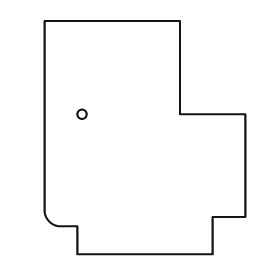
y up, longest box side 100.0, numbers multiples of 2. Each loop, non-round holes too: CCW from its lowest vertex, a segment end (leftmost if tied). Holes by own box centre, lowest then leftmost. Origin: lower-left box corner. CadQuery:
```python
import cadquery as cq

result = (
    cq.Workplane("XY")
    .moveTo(14.0, 0.0)
    .lineTo(72.0, 0.0)
    .lineTo(72.0, 16.0)
    .lineTo(86.0, 16.0)
    .lineTo(86.0, 60.0)
    .lineTo(58.0, 60.0)
    .lineTo(58.0, 100.0)
    .lineTo(0.0, 100.0)
    .lineTo(0.0, 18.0)
    .threePointArc((2.0, 14.0), (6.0, 12.0))
    .lineTo(14.0, 12.0)
    .close()
    .moveTo(16.0, 60.0)
    .circle(2.0)
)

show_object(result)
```